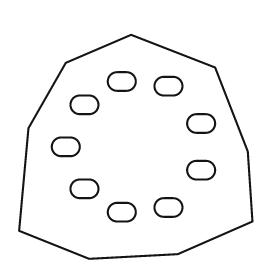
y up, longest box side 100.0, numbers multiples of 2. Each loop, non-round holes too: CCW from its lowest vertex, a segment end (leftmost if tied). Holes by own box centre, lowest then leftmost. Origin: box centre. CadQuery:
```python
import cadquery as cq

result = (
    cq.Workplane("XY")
    .moveTo(-20.0, -48.0)
    .lineTo(18.0, -46.0)
    .lineTo(50.0, -32.0)
    .lineTo(48.0, -2.0)
    .lineTo(34.0, 34.0)
    .lineTo(-2.0, 48.0)
    .lineTo(-30.0, 36.0)
    .lineTo(-46.0, 8.0)
    .lineTo(-50.0, -36.0)
    .close()
    .moveTo(-8.0, -32.0)
    .lineTo(-4.0, -32.0)
    .threePointArc((0.0, -28.0), (-4.0, -24.0))
    .lineTo(-8.0, -24.0)
    .threePointArc((-12.0, -28.0), (-8.0, -32.0))
    .close()
    .moveTo(12.0, -30.0)
    .lineTo(16.0, -30.0)
    .threePointArc((20.0, -26.0), (16.0, -22.0))
    .lineTo(12.0, -22.0)
    .threePointArc((8.0, -26.0), (12.0, -30.0))
    .close()
    .moveTo(-24.0, -22.0)
    .lineTo(-20.0, -22.0)
    .threePointArc((-16.0, -18.0), (-20.0, -14.0))
    .lineTo(-24.0, -14.0)
    .threePointArc((-28.0, -18.0), (-24.0, -22.0))
    .close()
    .moveTo(26.0, -14.0)
    .lineTo(30.0, -14.0)
    .threePointArc((34.0, -10.0), (30.0, -6.0))
    .lineTo(26.0, -6.0)
    .threePointArc((22.0, -10.0), (26.0, -14.0))
    .close()
    .moveTo(-32.0, -4.0)
    .lineTo(-28.0, -4.0)
    .threePointArc((-24.0, 0.0), (-28.0, 4.0))
    .lineTo(-32.0, 4.0)
    .threePointArc((-36.0, 0.0), (-32.0, -4.0))
    .close()
    .moveTo(26.0, 6.0)
    .lineTo(30.0, 6.0)
    .threePointArc((34.0, 10.0), (30.0, 14.0))
    .lineTo(26.0, 14.0)
    .threePointArc((22.0, 10.0), (26.0, 6.0))
    .close()
    .moveTo(-24.0, 14.0)
    .lineTo(-20.0, 14.0)
    .threePointArc((-16.0, 18.0), (-20.0, 22.0))
    .lineTo(-24.0, 22.0)
    .threePointArc((-28.0, 18.0), (-24.0, 14.0))
    .close()
    .moveTo(12.0, 22.0)
    .lineTo(16.0, 22.0)
    .threePointArc((20.0, 26.0), (16.0, 30.0))
    .lineTo(12.0, 30.0)
    .threePointArc((8.0, 26.0), (12.0, 22.0))
    .close()
    .moveTo(-8.0, 24.0)
    .lineTo(-4.0, 24.0)
    .threePointArc((0.0, 28.0), (-4.0, 32.0))
    .lineTo(-8.0, 32.0)
    .threePointArc((-12.0, 28.0), (-8.0, 24.0))
    .close()
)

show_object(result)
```